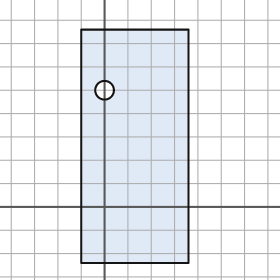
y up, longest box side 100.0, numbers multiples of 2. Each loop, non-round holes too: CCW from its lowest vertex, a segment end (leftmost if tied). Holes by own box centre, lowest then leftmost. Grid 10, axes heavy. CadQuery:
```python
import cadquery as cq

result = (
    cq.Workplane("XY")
    .moveTo(-10.0, -24.0)
    .lineTo(36.0, -24.0)
    .lineTo(36.0, 76.0)
    .lineTo(-10.0, 76.0)
    .close()
    .moveTo(0.0, 50.0)
    .circle(4.0)
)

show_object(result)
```